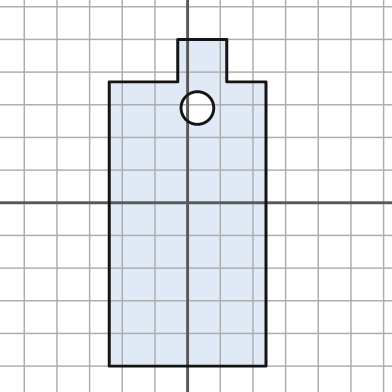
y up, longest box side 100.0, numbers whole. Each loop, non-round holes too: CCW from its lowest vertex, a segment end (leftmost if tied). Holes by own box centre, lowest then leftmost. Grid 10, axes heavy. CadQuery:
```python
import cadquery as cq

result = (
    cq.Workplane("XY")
    .moveTo(-24.0, -50.0)
    .lineTo(24.0, -50.0)
    .lineTo(24.0, 37.0)
    .lineTo(12.0, 37.0)
    .lineTo(12.0, 50.0)
    .lineTo(-3.0, 50.0)
    .lineTo(-3.0, 37.0)
    .lineTo(-24.0, 37.0)
    .close()
    .moveTo(3.0, 29.0)
    .circle(5.0)
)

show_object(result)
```